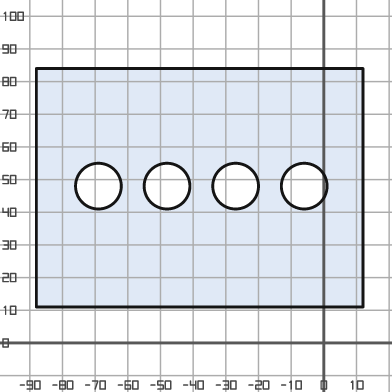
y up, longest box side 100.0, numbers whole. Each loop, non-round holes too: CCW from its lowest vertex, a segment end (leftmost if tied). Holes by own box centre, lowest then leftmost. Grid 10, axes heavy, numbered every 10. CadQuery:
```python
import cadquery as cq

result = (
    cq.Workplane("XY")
    .moveTo(-88.0, 11.0)
    .lineTo(12.0, 11.0)
    .lineTo(12.0, 84.0)
    .lineTo(-88.0, 84.0)
    .close()
    .moveTo(-69.0, 48.0)
    .circle(7.0)
    .moveTo(-48.0, 48.0)
    .circle(7.0)
    .moveTo(-27.0, 48.0)
    .circle(7.0)
    .moveTo(-6.0, 48.0)
    .circle(7.0)
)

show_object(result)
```